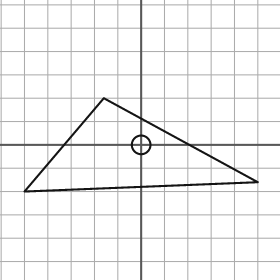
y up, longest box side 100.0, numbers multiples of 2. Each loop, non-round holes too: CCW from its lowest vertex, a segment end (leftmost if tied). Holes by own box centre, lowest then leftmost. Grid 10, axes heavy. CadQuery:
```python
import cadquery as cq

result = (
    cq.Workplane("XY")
    .moveTo(-50.0, -20.0)
    .lineTo(50.0, -16.0)
    .lineTo(-16.0, 20.0)
    .close()
    .moveTo(0.0, 0.0)
    .circle(4.0)
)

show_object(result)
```